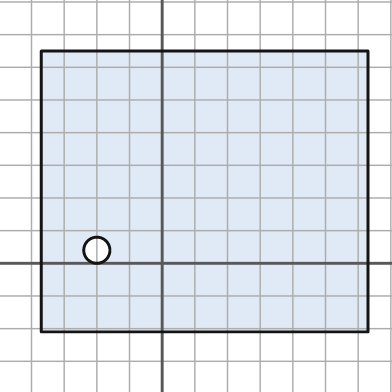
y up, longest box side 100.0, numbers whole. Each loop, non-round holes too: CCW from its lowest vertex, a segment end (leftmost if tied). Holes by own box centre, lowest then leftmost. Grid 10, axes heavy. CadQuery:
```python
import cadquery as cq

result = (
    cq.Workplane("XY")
    .moveTo(-37.0, -21.0)
    .lineTo(63.0, -21.0)
    .lineTo(63.0, 65.0)
    .lineTo(-37.0, 65.0)
    .close()
    .moveTo(-20.0, 4.0)
    .circle(4.0)
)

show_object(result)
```